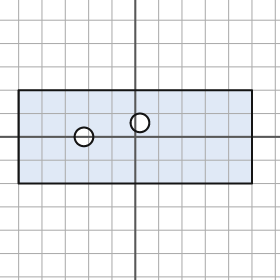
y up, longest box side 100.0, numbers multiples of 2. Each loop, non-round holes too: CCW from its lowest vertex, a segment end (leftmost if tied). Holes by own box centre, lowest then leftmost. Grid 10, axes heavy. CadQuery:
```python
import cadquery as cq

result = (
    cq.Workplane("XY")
    .moveTo(-50.0, -20.0)
    .lineTo(50.0, -20.0)
    .lineTo(50.0, 20.0)
    .lineTo(-50.0, 20.0)
    .close()
    .moveTo(-22.0, 0.0)
    .circle(4.0)
    .moveTo(2.0, 6.0)
    .circle(4.0)
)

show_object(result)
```